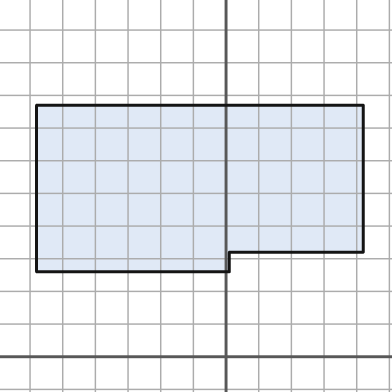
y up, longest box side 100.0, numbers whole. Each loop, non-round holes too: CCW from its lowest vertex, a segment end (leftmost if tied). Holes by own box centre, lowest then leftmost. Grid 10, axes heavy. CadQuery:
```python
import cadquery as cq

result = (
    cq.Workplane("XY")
    .moveTo(-58.0, 26.0)
    .lineTo(1.0, 26.0)
    .lineTo(1.0, 32.0)
    .lineTo(42.0, 32.0)
    .lineTo(42.0, 77.0)
    .lineTo(-58.0, 77.0)
    .close()
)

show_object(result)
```